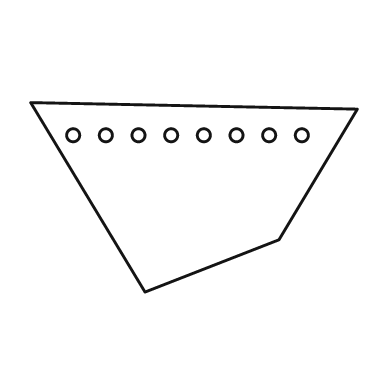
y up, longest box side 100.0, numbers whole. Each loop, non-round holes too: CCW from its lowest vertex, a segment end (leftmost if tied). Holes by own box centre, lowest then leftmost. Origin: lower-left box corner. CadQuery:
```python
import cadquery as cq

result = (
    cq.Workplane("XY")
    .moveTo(35.0, 0.0)
    .lineTo(76.0, 16.0)
    .lineTo(100.0, 56.0)
    .lineTo(0.0, 58.0)
    .close()
    .moveTo(13.0, 48.0)
    .circle(2.0)
    .moveTo(23.0, 48.0)
    .circle(2.0)
    .moveTo(33.0, 48.0)
    .circle(2.0)
    .moveTo(43.0, 48.0)
    .circle(2.0)
    .moveTo(53.0, 48.0)
    .circle(2.0)
    .moveTo(63.0, 48.0)
    .circle(2.0)
    .moveTo(73.0, 48.0)
    .circle(2.0)
    .moveTo(83.0, 48.0)
    .circle(2.0)
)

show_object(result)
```